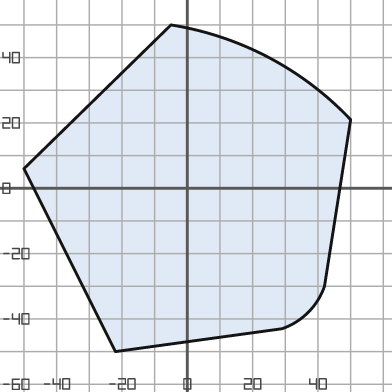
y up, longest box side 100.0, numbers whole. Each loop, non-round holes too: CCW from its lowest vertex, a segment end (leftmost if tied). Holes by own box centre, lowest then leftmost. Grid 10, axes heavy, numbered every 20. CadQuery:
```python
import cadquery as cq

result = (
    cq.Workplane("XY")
    .moveTo(-22.0, -50.0)
    .lineTo(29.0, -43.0)
    .threePointArc((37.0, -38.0), (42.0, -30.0))
    .lineTo(50.0, 21.0)
    .threePointArc((25.0, 40.0), (-5.0, 50.0))
    .lineTo(-50.0, 6.0)
    .close()
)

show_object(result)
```